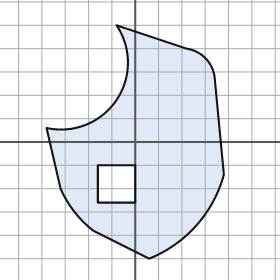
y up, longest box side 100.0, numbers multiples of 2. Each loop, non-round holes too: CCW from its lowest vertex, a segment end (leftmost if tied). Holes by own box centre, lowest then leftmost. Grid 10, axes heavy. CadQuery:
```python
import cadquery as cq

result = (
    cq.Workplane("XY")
    .moveTo(6.0, -50.0)
    .threePointArc((26.0, -36.0), (38.0, -14.0))
    .lineTo(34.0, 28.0)
    .threePointArc((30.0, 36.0), (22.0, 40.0))
    .lineTo(-8.0, 50.0)
    .threePointArc((-8.0, 18.0), (-38.0, 6.0))
    .lineTo(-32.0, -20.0)
    .threePointArc((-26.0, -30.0), (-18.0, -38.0))
    .close()
    .moveTo(-16.0, -26.0)
    .lineTo(0.0, -26.0)
    .lineTo(0.0, -10.0)
    .lineTo(-16.0, -10.0)
    .close()
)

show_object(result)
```